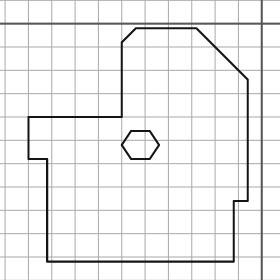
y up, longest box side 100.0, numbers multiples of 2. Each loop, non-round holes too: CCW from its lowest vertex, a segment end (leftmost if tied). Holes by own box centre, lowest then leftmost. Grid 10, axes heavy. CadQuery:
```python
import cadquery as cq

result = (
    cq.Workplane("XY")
    .moveTo(-92.0, -102.0)
    .lineTo(-12.0, -102.0)
    .lineTo(-12.0, -76.0)
    .lineTo(-6.0, -76.0)
    .lineTo(-6.0, -24.0)
    .lineTo(-28.0, -2.0)
    .lineTo(-54.0, -2.0)
    .lineTo(-60.0, -8.0)
    .lineTo(-60.0, -40.0)
    .lineTo(-100.0, -40.0)
    .lineTo(-100.0, -58.0)
    .lineTo(-92.0, -58.0)
    .close()
    .moveTo(-56.0, -58.0)
    .lineTo(-48.0, -58.0)
    .lineTo(-44.0, -52.0)
    .lineTo(-48.0, -46.0)
    .lineTo(-56.0, -46.0)
    .lineTo(-60.0, -52.0)
    .close()
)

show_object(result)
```